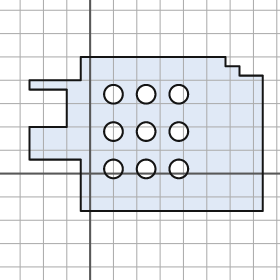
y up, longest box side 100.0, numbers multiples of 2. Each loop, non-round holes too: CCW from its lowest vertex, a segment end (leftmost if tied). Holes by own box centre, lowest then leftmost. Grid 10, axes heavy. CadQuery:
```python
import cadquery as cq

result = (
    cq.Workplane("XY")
    .moveTo(-4.0, -16.0)
    .lineTo(74.0, -16.0)
    .lineTo(74.0, 42.0)
    .lineTo(64.0, 42.0)
    .lineTo(64.0, 46.0)
    .lineTo(58.0, 46.0)
    .lineTo(58.0, 50.0)
    .lineTo(-4.0, 50.0)
    .lineTo(-4.0, 40.0)
    .lineTo(-26.0, 40.0)
    .lineTo(-26.0, 36.0)
    .lineTo(-10.0, 36.0)
    .lineTo(-10.0, 20.0)
    .lineTo(-26.0, 20.0)
    .lineTo(-26.0, 6.0)
    .lineTo(-4.0, 6.0)
    .close()
    .moveTo(10.0, 2.0)
    .circle(4.0)
    .moveTo(24.0, 2.0)
    .circle(4.0)
    .moveTo(38.0, 2.0)
    .circle(4.0)
    .moveTo(10.0, 18.0)
    .circle(4.0)
    .moveTo(24.0, 18.0)
    .circle(4.0)
    .moveTo(38.0, 18.0)
    .circle(4.0)
    .moveTo(10.0, 34.0)
    .circle(4.0)
    .moveTo(24.0, 34.0)
    .circle(4.0)
    .moveTo(38.0, 34.0)
    .circle(4.0)
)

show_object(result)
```